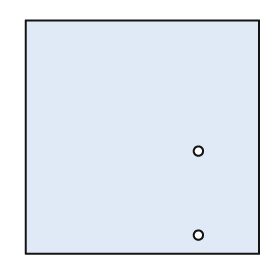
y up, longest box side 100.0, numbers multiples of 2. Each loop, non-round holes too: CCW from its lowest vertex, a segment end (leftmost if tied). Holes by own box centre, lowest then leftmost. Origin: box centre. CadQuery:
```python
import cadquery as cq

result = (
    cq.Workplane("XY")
    .moveTo(-50.0, -50.0)
    .lineTo(50.0, -50.0)
    .lineTo(50.0, 50.0)
    .lineTo(-50.0, 50.0)
    .close()
    .moveTo(24.0, -42.0)
    .circle(2.0)
    .moveTo(24.0, -6.0)
    .circle(2.0)
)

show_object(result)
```